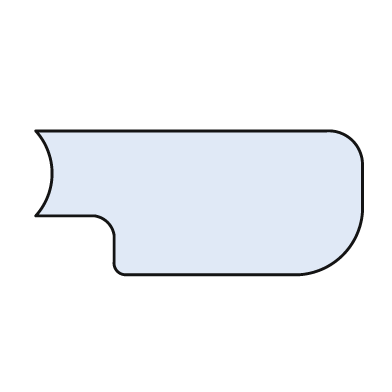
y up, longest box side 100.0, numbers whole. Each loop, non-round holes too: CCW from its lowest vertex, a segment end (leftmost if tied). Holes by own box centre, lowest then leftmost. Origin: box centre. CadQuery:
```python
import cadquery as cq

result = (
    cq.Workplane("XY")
    .moveTo(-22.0, -22.0)
    .lineTo(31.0, -22.0)
    .threePointArc((44.0, -16.0), (50.0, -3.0))
    .lineTo(50.0, 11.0)
    .threePointArc((47.0, 19.0), (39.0, 22.0))
    .lineTo(-50.0, 22.0)
    .threePointArc((-45.0, 9.0), (-50.0, -4.0))
    .lineTo(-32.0, -4.0)
    .threePointArc((-28.0, -6.0), (-26.0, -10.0))
    .lineTo(-26.0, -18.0)
    .threePointArc((-25.0, -21.0), (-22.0, -22.0))
    .close()
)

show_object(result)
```